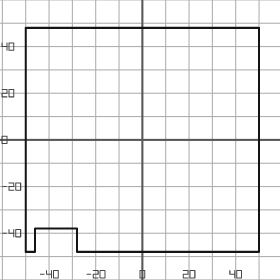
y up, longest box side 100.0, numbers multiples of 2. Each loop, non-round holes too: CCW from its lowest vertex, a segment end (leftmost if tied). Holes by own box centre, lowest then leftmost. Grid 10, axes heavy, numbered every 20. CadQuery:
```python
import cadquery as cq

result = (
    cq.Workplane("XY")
    .moveTo(-50.0, -48.0)
    .lineTo(-46.0, -48.0)
    .lineTo(-46.0, -38.0)
    .lineTo(-28.0, -38.0)
    .lineTo(-28.0, -48.0)
    .lineTo(50.0, -48.0)
    .lineTo(50.0, 48.0)
    .lineTo(-50.0, 48.0)
    .close()
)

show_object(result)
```